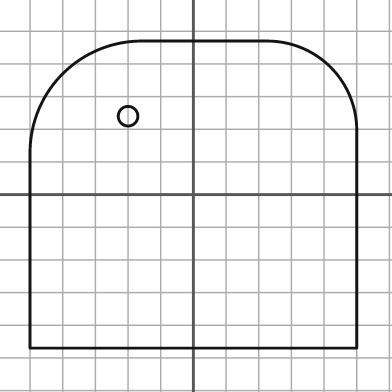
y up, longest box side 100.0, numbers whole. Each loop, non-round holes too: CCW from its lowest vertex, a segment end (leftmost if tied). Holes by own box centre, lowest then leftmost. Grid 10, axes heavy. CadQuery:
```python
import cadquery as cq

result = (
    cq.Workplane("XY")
    .moveTo(-50.0, -47.0)
    .lineTo(50.0, -47.0)
    .lineTo(50.0, 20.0)
    .threePointArc((42.0, 39.0), (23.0, 47.0))
    .lineTo(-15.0, 47.0)
    .threePointArc((-40.0, 37.0), (-50.0, 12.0))
    .close()
    .moveTo(-20.0, 24.0)
    .circle(3.0)
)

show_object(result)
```